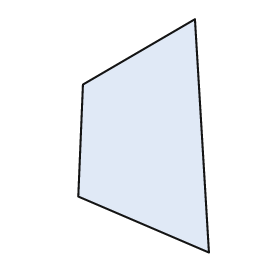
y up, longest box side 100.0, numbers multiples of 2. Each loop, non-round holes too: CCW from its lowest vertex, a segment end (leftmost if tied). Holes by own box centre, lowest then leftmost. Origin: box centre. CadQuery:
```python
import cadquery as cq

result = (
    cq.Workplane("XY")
    .moveTo(28.0, -50.0)
    .lineTo(22.0, 50.0)
    .lineTo(-26.0, 22.0)
    .lineTo(-28.0, -26.0)
    .close()
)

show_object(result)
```